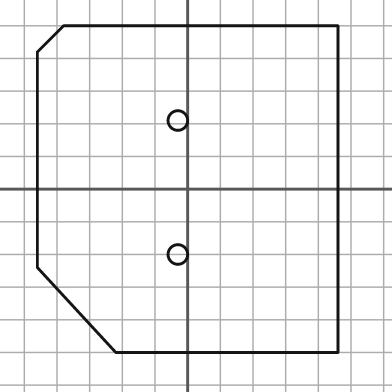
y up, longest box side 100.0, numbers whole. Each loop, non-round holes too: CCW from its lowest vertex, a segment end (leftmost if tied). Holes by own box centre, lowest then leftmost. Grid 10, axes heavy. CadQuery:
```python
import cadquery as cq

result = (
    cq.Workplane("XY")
    .moveTo(-22.0, -50.0)
    .lineTo(46.0, -50.0)
    .lineTo(46.0, 50.0)
    .lineTo(-38.0, 50.0)
    .lineTo(-46.0, 42.0)
    .lineTo(-46.0, -24.0)
    .close()
    .moveTo(-3.0, -20.0)
    .circle(3.0)
    .moveTo(-3.0, 21.0)
    .circle(3.0)
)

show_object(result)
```